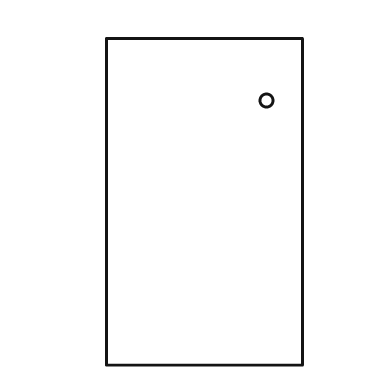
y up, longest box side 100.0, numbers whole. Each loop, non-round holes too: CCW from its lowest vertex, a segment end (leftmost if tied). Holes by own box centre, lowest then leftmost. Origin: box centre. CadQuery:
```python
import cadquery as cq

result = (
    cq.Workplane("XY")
    .moveTo(-30.0, -50.0)
    .lineTo(30.0, -50.0)
    .lineTo(30.0, 50.0)
    .lineTo(-30.0, 50.0)
    .close()
    .moveTo(19.0, 31.0)
    .circle(2.0)
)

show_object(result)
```